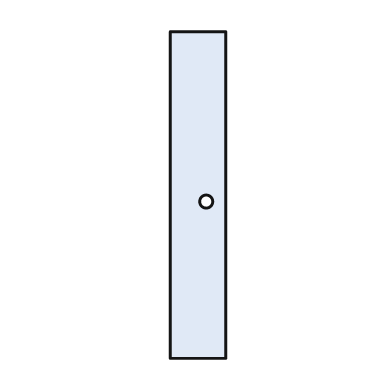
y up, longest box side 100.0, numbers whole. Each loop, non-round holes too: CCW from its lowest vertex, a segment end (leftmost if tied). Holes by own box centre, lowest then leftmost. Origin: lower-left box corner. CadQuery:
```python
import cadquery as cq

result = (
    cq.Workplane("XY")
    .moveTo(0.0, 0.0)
    .lineTo(17.0, 0.0)
    .lineTo(17.0, 100.0)
    .lineTo(0.0, 100.0)
    .close()
    .moveTo(11.0, 48.0)
    .circle(2.0)
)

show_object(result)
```